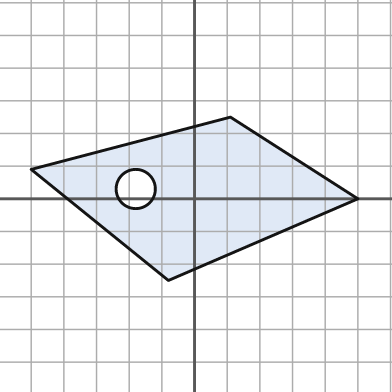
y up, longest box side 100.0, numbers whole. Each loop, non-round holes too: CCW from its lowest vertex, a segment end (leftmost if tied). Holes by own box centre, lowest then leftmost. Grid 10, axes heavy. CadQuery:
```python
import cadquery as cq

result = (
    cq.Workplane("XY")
    .moveTo(-8.0, -25.0)
    .lineTo(50.0, 0.0)
    .lineTo(11.0, 25.0)
    .lineTo(-50.0, 9.0)
    .close()
    .moveTo(-18.0, 3.0)
    .circle(6.0)
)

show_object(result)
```